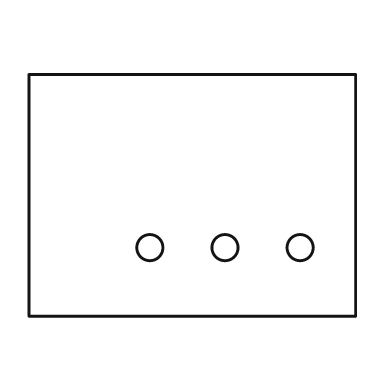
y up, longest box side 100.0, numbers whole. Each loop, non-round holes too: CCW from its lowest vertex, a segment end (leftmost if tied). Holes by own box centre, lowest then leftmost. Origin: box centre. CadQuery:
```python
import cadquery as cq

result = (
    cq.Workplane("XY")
    .moveTo(-50.0, -37.0)
    .lineTo(50.0, -37.0)
    .lineTo(50.0, 37.0)
    .lineTo(-50.0, 37.0)
    .close()
    .moveTo(-13.0, -16.0)
    .circle(4.0)
    .moveTo(10.0, -16.0)
    .circle(4.0)
    .moveTo(33.0, -16.0)
    .circle(4.0)
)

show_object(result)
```